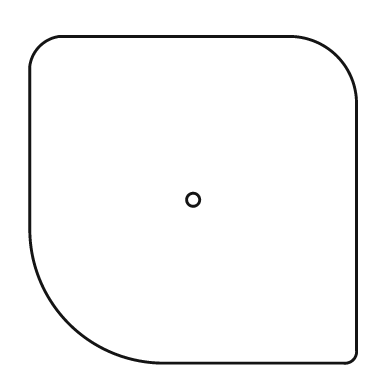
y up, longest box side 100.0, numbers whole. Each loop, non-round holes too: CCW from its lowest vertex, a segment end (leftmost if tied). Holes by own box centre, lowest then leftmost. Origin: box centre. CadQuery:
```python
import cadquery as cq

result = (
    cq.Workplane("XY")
    .moveTo(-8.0, -50.0)
    .lineTo(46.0, -50.0)
    .threePointArc((49.0, -49.0), (50.0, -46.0))
    .lineTo(50.0, 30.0)
    .threePointArc((44.0, 44.0), (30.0, 50.0))
    .lineTo(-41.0, 50.0)
    .threePointArc((-47.0, 47.0), (-50.0, 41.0))
    .lineTo(-50.0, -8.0)
    .threePointArc((-38.0, -38.0), (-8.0, -50.0))
    .close()
    .moveTo(0.0, 0.0)
    .circle(2.0)
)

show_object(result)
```